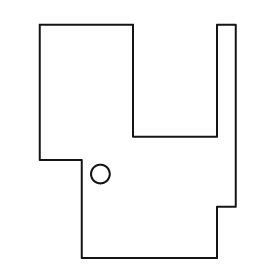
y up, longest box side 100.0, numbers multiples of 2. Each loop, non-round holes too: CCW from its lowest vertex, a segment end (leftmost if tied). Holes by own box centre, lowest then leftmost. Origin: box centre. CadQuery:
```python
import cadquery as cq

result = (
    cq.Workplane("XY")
    .moveTo(-24.0, -50.0)
    .lineTo(34.0, -50.0)
    .lineTo(34.0, -28.0)
    .lineTo(42.0, -28.0)
    .lineTo(42.0, 50.0)
    .lineTo(34.0, 50.0)
    .lineTo(34.0, 2.0)
    .lineTo(-2.0, 2.0)
    .lineTo(-2.0, 50.0)
    .lineTo(-42.0, 50.0)
    .lineTo(-42.0, -8.0)
    .lineTo(-24.0, -8.0)
    .close()
    .moveTo(-16.0, -14.0)
    .circle(4.0)
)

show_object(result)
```